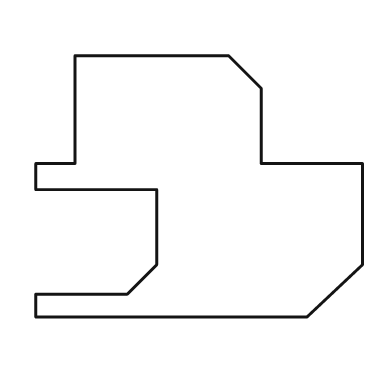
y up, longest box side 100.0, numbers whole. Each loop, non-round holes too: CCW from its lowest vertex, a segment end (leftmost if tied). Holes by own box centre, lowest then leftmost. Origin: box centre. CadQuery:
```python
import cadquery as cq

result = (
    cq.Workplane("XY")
    .moveTo(-50.0, -40.0)
    .lineTo(33.0, -40.0)
    .lineTo(50.0, -24.0)
    .lineTo(50.0, 7.0)
    .lineTo(19.0, 7.0)
    .lineTo(19.0, 30.0)
    .lineTo(9.0, 40.0)
    .lineTo(-38.0, 40.0)
    .lineTo(-38.0, 7.0)
    .lineTo(-50.0, 7.0)
    .lineTo(-50.0, -1.0)
    .lineTo(-13.0, -1.0)
    .lineTo(-13.0, -24.0)
    .lineTo(-22.0, -33.0)
    .lineTo(-50.0, -33.0)
    .close()
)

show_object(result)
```